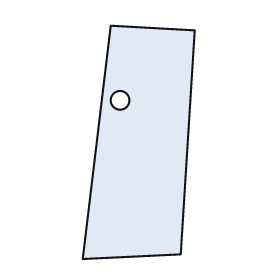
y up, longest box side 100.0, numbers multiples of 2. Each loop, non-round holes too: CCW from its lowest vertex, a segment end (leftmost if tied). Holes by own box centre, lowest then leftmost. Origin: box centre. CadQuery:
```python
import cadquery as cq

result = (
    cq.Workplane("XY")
    .moveTo(-24.0, -50.0)
    .lineTo(18.0, -48.0)
    .lineTo(24.0, 48.0)
    .lineTo(-12.0, 50.0)
    .close()
    .moveTo(-8.0, 18.0)
    .circle(4.0)
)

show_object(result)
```